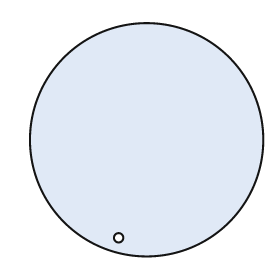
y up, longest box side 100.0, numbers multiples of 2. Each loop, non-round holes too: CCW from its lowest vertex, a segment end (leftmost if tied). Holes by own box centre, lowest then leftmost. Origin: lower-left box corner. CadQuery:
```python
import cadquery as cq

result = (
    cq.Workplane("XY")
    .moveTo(50.0, 50.0)
    .circle(50.0)
    .moveTo(38.0, 8.0)
    .circle(2.0)
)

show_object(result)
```